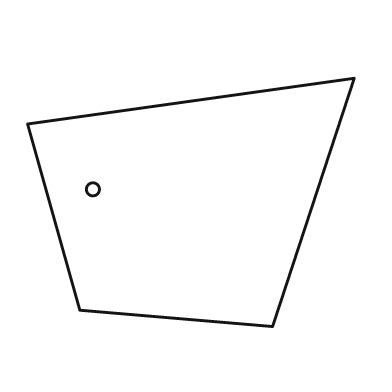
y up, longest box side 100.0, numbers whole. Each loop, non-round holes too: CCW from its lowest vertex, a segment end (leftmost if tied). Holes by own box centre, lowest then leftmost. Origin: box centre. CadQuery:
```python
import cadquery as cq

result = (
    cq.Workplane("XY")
    .moveTo(25.0, -38.0)
    .lineTo(50.0, 38.0)
    .lineTo(-50.0, 24.0)
    .lineTo(-34.0, -33.0)
    .close()
    .moveTo(-30.0, 4.0)
    .circle(2.0)
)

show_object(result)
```